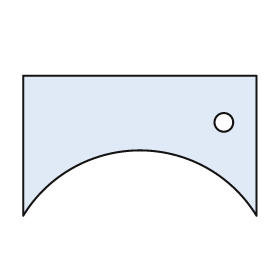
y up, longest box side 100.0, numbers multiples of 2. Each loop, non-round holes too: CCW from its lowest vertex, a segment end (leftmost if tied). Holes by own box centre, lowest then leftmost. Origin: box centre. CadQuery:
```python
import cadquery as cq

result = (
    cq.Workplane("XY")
    .moveTo(-50.0, -30.0)
    .threePointArc((0.0, -2.0), (50.0, -30.0))
    .lineTo(50.0, 30.0)
    .lineTo(-50.0, 30.0)
    .close()
    .moveTo(36.0, 10.0)
    .circle(4.0)
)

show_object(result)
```